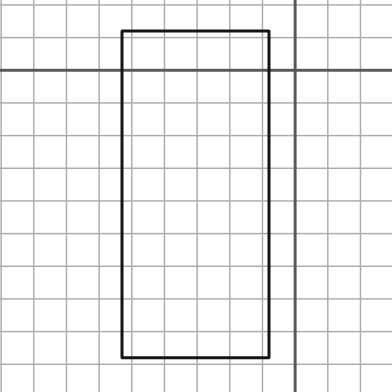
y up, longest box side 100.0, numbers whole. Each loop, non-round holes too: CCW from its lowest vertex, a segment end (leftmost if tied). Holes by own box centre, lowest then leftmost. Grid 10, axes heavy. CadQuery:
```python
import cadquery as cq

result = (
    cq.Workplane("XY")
    .moveTo(-53.0, -88.0)
    .lineTo(-8.0, -88.0)
    .lineTo(-8.0, 12.0)
    .lineTo(-53.0, 12.0)
    .close()
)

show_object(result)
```